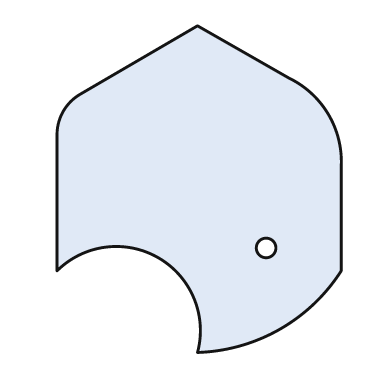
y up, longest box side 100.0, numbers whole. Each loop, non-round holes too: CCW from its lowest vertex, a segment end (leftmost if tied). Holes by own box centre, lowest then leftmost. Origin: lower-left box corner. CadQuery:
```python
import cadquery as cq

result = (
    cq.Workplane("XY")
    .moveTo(43.0, 0.0)
    .threePointArc((68.0, 7.0), (87.0, 25.0))
    .lineTo(87.0, 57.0)
    .threePointArc((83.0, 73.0), (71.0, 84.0))
    .lineTo(43.0, 100.0)
    .lineTo(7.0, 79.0)
    .threePointArc((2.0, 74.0), (0.0, 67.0))
    .lineTo(0.0, 25.0)
    .threePointArc((31.0, 29.0), (43.0, 0.0))
    .close()
    .moveTo(64.0, 32.0)
    .circle(3.0)
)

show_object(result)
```